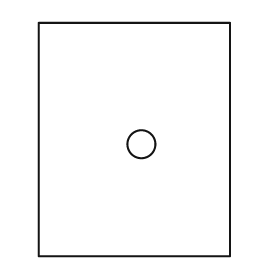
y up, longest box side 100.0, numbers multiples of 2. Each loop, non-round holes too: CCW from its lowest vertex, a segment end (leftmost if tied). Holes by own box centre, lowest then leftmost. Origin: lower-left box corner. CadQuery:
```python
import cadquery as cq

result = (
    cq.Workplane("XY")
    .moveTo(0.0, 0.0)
    .lineTo(82.0, 0.0)
    .lineTo(82.0, 100.0)
    .lineTo(0.0, 100.0)
    .close()
    .moveTo(44.0, 48.0)
    .circle(6.0)
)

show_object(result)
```